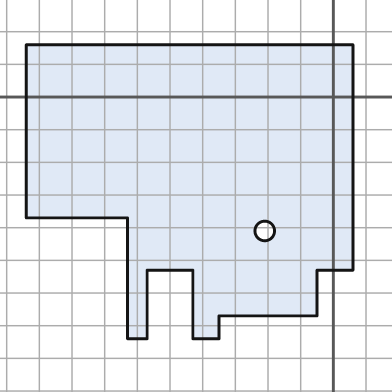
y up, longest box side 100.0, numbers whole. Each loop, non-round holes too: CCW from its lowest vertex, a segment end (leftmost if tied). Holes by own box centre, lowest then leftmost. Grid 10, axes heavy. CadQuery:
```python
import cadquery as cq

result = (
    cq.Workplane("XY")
    .moveTo(-63.0, -74.0)
    .lineTo(-57.0, -74.0)
    .lineTo(-57.0, -53.0)
    .lineTo(-43.0, -53.0)
    .lineTo(-43.0, -74.0)
    .lineTo(-35.0, -74.0)
    .lineTo(-35.0, -67.0)
    .lineTo(-5.0, -67.0)
    .lineTo(-5.0, -53.0)
    .lineTo(6.0, -53.0)
    .lineTo(6.0, 16.0)
    .lineTo(-94.0, 16.0)
    .lineTo(-94.0, -37.0)
    .lineTo(-63.0, -37.0)
    .close()
    .moveTo(-21.0, -41.0)
    .circle(3.0)
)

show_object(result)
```